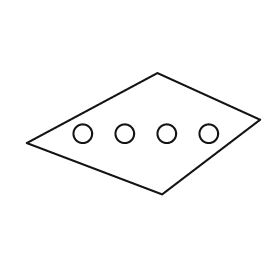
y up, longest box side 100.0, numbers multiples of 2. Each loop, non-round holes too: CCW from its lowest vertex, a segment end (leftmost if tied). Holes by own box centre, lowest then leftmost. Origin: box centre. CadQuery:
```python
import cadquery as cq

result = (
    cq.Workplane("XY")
    .moveTo(8.0, -26.0)
    .lineTo(50.0, 6.0)
    .lineTo(6.0, 26.0)
    .lineTo(-50.0, -4.0)
    .close()
    .moveTo(-26.0, 0.0)
    .circle(4.0)
    .moveTo(-8.0, 0.0)
    .circle(4.0)
    .moveTo(10.0, 0.0)
    .circle(4.0)
    .moveTo(28.0, 0.0)
    .circle(4.0)
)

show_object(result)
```